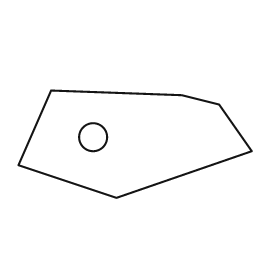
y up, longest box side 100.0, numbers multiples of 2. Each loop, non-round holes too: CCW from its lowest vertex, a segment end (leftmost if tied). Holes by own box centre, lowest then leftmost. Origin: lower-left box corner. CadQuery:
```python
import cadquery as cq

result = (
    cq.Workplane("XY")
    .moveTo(42.0, 0.0)
    .lineTo(100.0, 20.0)
    .lineTo(86.0, 40.0)
    .lineTo(70.0, 44.0)
    .lineTo(14.0, 46.0)
    .lineTo(0.0, 14.0)
    .close()
    .moveTo(32.0, 26.0)
    .circle(6.0)
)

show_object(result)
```